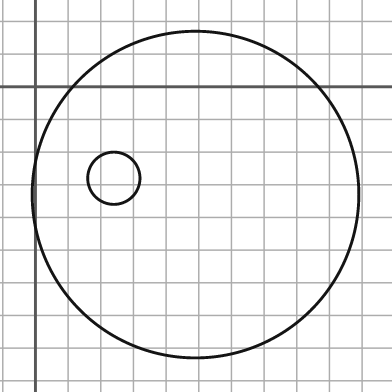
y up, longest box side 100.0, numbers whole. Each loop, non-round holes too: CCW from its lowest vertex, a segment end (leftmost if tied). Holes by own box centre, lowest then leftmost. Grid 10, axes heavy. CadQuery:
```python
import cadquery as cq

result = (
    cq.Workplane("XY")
    .moveTo(49.0, -33.0)
    .circle(50.0)
    .moveTo(24.0, -28.0)
    .circle(8.0)
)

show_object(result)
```